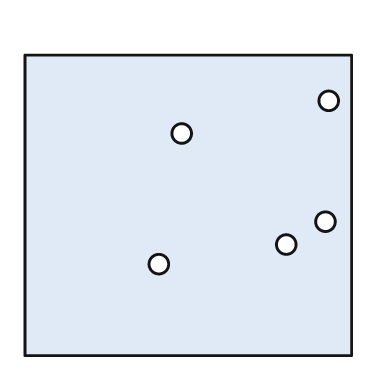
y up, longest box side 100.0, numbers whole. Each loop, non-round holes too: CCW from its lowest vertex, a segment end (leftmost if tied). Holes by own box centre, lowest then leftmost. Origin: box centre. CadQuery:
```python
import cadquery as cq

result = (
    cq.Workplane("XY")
    .moveTo(-50.0, -46.0)
    .lineTo(50.0, -46.0)
    .lineTo(50.0, 46.0)
    .lineTo(-50.0, 46.0)
    .close()
    .moveTo(-9.0, -18.0)
    .circle(3.0)
    .moveTo(30.0, -12.0)
    .circle(3.0)
    .moveTo(42.0, -5.0)
    .circle(3.0)
    .moveTo(-2.0, 22.0)
    .circle(3.0)
    .moveTo(43.0, 32.0)
    .circle(3.0)
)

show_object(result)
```